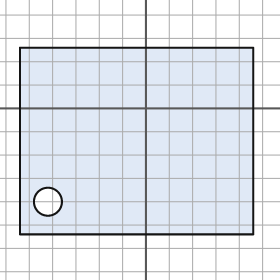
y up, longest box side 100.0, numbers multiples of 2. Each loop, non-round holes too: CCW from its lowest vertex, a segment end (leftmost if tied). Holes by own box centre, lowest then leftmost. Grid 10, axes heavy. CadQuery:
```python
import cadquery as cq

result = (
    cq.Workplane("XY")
    .moveTo(-54.0, -54.0)
    .lineTo(46.0, -54.0)
    .lineTo(46.0, 26.0)
    .lineTo(-54.0, 26.0)
    .close()
    .moveTo(-42.0, -40.0)
    .circle(6.0)
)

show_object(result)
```